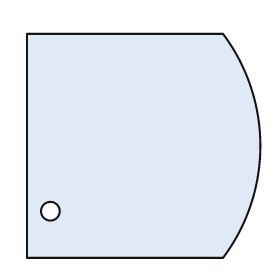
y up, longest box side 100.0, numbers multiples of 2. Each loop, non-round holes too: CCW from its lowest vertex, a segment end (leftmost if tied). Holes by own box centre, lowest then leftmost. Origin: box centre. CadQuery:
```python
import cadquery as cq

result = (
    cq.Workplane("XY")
    .moveTo(-50.0, -48.0)
    .lineTo(34.0, -48.0)
    .threePointArc((50.0, 0.0), (34.0, 48.0))
    .lineTo(-50.0, 48.0)
    .close()
    .moveTo(-40.0, -28.0)
    .circle(4.0)
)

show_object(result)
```